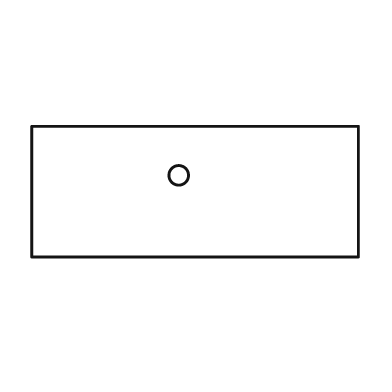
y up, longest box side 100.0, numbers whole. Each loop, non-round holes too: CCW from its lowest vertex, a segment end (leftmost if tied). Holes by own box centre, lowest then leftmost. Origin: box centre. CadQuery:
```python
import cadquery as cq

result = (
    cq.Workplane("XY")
    .moveTo(-50.0, -20.0)
    .lineTo(50.0, -20.0)
    .lineTo(50.0, 20.0)
    .lineTo(-50.0, 20.0)
    .close()
    .moveTo(-5.0, 5.0)
    .circle(3.0)
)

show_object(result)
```